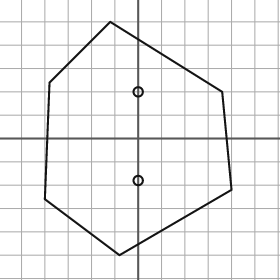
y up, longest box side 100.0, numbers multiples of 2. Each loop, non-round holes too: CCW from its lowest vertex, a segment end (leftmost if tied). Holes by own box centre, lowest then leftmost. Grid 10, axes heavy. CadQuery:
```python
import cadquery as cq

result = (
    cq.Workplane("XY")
    .moveTo(-8.0, -50.0)
    .lineTo(40.0, -22.0)
    .lineTo(36.0, 20.0)
    .lineTo(-12.0, 50.0)
    .lineTo(-38.0, 24.0)
    .lineTo(-40.0, -26.0)
    .close()
    .moveTo(0.0, -18.0)
    .circle(2.0)
    .moveTo(0.0, 20.0)
    .circle(2.0)
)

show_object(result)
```